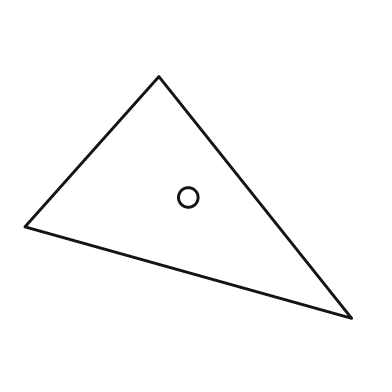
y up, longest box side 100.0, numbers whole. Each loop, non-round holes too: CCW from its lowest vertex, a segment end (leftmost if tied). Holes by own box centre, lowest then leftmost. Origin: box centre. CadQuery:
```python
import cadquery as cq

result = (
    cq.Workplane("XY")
    .moveTo(50.0, -37.0)
    .lineTo(-9.0, 37.0)
    .lineTo(-50.0, -9.0)
    .close()
    .moveTo(0.0, 0.0)
    .circle(3.0)
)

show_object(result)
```